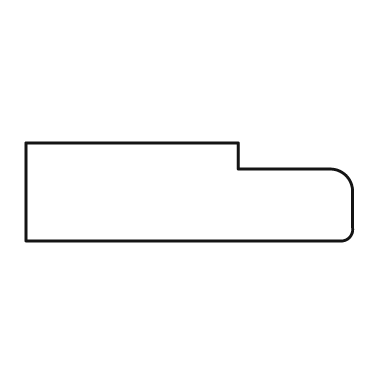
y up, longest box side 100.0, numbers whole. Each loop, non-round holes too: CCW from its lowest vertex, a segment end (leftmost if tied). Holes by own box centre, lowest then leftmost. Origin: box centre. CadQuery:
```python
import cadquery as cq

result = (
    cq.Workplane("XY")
    .moveTo(-50.0, -15.0)
    .lineTo(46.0, -15.0)
    .threePointArc((49.0, -14.0), (50.0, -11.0))
    .lineTo(50.0, 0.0)
    .threePointArc((48.0, 5.0), (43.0, 7.0))
    .lineTo(15.0, 7.0)
    .lineTo(15.0, 15.0)
    .lineTo(-50.0, 15.0)
    .close()
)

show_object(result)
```